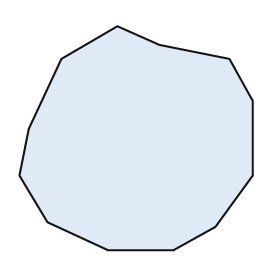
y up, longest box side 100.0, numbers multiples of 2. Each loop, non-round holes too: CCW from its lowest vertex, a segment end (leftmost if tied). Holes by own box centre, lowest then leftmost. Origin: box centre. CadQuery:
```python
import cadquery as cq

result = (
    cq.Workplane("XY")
    .moveTo(-12.0, -48.0)
    .lineTo(16.0, -48.0)
    .lineTo(34.0, -38.0)
    .lineTo(50.0, -16.0)
    .lineTo(50.0, 16.0)
    .lineTo(40.0, 34.0)
    .lineTo(10.0, 40.0)
    .lineTo(-8.0, 48.0)
    .lineTo(-32.0, 34.0)
    .lineTo(-46.0, 4.0)
    .lineTo(-50.0, -16.0)
    .lineTo(-38.0, -36.0)
    .close()
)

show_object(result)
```